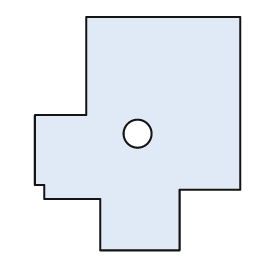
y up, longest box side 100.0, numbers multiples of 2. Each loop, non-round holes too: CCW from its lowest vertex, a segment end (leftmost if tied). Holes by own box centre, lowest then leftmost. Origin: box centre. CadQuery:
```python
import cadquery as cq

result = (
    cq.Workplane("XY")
    .moveTo(-16.0, -50.0)
    .lineTo(18.0, -50.0)
    .lineTo(18.0, -24.0)
    .lineTo(44.0, -24.0)
    .lineTo(44.0, 50.0)
    .lineTo(-22.0, 50.0)
    .lineTo(-22.0, 8.0)
    .lineTo(-44.0, 8.0)
    .lineTo(-44.0, -22.0)
    .lineTo(-40.0, -22.0)
    .lineTo(-40.0, -28.0)
    .lineTo(-16.0, -28.0)
    .close()
    .moveTo(0.0, 0.0)
    .circle(6.0)
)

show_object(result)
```